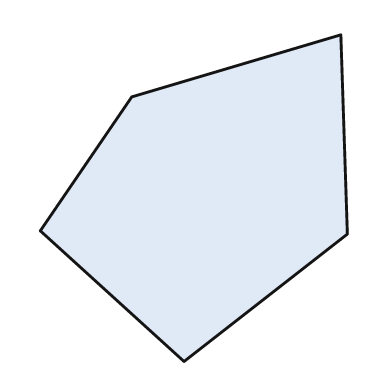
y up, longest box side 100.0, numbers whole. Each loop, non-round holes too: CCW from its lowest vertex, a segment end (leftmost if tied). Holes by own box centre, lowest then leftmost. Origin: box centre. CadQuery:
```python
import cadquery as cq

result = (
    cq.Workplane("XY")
    .moveTo(-3.0, -50.0)
    .lineTo(47.0, -11.0)
    .lineTo(45.0, 50.0)
    .lineTo(-19.0, 31.0)
    .lineTo(-47.0, -10.0)
    .close()
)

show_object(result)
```